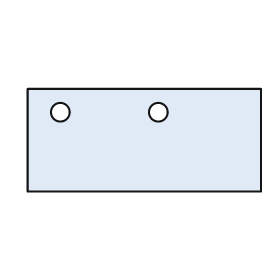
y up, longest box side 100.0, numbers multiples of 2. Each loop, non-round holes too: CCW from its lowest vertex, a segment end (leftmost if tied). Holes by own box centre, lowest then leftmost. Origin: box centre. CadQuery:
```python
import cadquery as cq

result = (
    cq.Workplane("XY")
    .moveTo(-50.0, -22.0)
    .lineTo(50.0, -22.0)
    .lineTo(50.0, 22.0)
    .lineTo(-50.0, 22.0)
    .close()
    .moveTo(-36.0, 12.0)
    .circle(4.0)
    .moveTo(6.0, 12.0)
    .circle(4.0)
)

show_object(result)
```